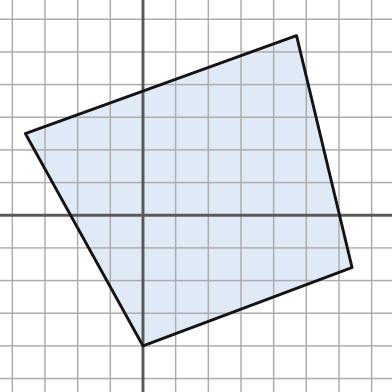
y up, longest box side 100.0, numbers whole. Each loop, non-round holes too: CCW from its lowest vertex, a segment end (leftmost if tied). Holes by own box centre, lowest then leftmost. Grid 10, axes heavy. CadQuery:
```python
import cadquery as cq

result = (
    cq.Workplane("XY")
    .moveTo(0.0, -40.0)
    .lineTo(64.0, -16.0)
    .lineTo(47.0, 55.0)
    .lineTo(-36.0, 25.0)
    .close()
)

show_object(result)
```